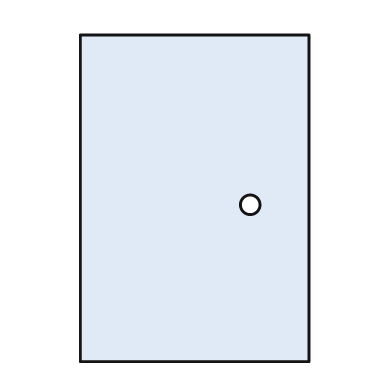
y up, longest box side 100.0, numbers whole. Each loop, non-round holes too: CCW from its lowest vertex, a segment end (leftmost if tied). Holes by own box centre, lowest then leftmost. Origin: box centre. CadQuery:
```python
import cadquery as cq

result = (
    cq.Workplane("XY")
    .moveTo(-35.0, -50.0)
    .lineTo(35.0, -50.0)
    .lineTo(35.0, 50.0)
    .lineTo(-35.0, 50.0)
    .close()
    .moveTo(17.0, -2.0)
    .circle(3.0)
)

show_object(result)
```